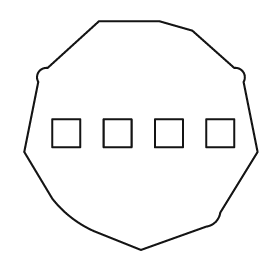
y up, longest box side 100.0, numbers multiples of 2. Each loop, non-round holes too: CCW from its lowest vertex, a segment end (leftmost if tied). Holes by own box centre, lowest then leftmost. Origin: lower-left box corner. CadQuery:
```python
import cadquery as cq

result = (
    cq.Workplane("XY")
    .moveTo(50.0, 0.0)
    .lineTo(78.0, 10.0)
    .threePointArc((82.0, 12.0), (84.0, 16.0))
    .lineTo(100.0, 42.0)
    .lineTo(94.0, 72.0)
    .threePointArc((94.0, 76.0), (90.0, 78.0))
    .lineTo(72.0, 94.0)
    .lineTo(58.0, 98.0)
    .lineTo(32.0, 98.0)
    .lineTo(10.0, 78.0)
    .threePointArc((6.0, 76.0), (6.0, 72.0))
    .lineTo(0.0, 42.0)
    .lineTo(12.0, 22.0)
    .threePointArc((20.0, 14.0), (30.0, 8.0))
    .close()
    .moveTo(12.0, 44.0)
    .lineTo(24.0, 44.0)
    .lineTo(24.0, 56.0)
    .lineTo(12.0, 56.0)
    .close()
    .moveTo(34.0, 44.0)
    .lineTo(46.0, 44.0)
    .lineTo(46.0, 56.0)
    .lineTo(34.0, 56.0)
    .close()
    .moveTo(56.0, 44.0)
    .lineTo(68.0, 44.0)
    .lineTo(68.0, 56.0)
    .lineTo(56.0, 56.0)
    .close()
    .moveTo(78.0, 44.0)
    .lineTo(90.0, 44.0)
    .lineTo(90.0, 56.0)
    .lineTo(78.0, 56.0)
    .close()
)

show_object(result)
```